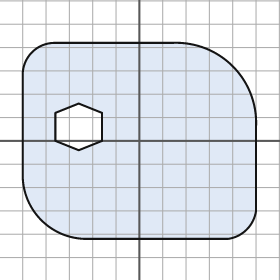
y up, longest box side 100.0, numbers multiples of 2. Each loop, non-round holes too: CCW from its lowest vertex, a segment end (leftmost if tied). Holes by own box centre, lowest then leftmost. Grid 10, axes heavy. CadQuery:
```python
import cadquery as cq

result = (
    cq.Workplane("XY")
    .moveTo(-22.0, -42.0)
    .lineTo(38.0, -42.0)
    .threePointArc((46.0, -38.0), (50.0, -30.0))
    .lineTo(50.0, 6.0)
    .threePointArc((40.0, 32.0), (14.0, 42.0))
    .lineTo(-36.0, 42.0)
    .threePointArc((-46.0, 38.0), (-50.0, 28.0))
    .lineTo(-50.0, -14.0)
    .threePointArc((-42.0, -34.0), (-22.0, -42.0))
    .close()
    .moveTo(-26.0, -4.0)
    .lineTo(-16.0, 0.0)
    .lineTo(-16.0, 12.0)
    .lineTo(-26.0, 16.0)
    .lineTo(-36.0, 12.0)
    .lineTo(-36.0, 0.0)
    .close()
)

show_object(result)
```